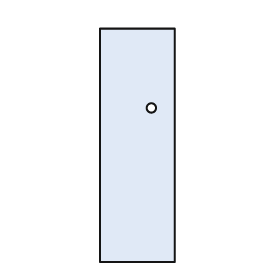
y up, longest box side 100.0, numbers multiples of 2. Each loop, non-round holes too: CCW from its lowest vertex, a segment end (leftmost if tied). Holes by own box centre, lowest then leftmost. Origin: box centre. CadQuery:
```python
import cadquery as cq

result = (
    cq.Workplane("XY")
    .moveTo(-16.0, -50.0)
    .lineTo(16.0, -50.0)
    .lineTo(16.0, 50.0)
    .lineTo(-16.0, 50.0)
    .close()
    .moveTo(6.0, 16.0)
    .circle(2.0)
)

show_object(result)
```